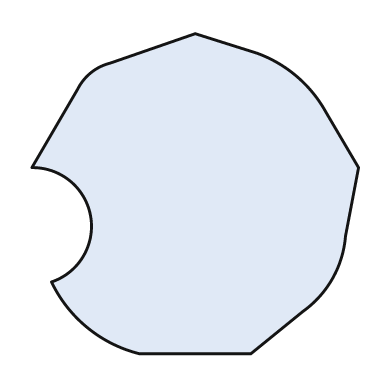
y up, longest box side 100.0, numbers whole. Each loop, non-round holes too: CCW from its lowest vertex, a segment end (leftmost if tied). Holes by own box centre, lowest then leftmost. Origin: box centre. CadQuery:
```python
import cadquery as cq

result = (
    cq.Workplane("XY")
    .moveTo(-17.0, -49.0)
    .lineTo(17.0, -49.0)
    .lineTo(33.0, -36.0)
    .threePointArc((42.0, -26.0), (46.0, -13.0))
    .lineTo(50.0, 8.0)
    .lineTo(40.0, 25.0)
    .threePointArc((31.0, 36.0), (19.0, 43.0))
    .lineTo(0.0, 49.0)
    .lineTo(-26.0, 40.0)
    .threePointArc((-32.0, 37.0), (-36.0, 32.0))
    .lineTo(-50.0, 8.0)
    .threePointArc((-32.0, -7.0), (-44.0, -27.0))
    .threePointArc((-33.0, -41.0), (-17.0, -49.0))
    .close()
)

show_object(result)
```